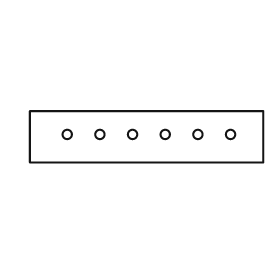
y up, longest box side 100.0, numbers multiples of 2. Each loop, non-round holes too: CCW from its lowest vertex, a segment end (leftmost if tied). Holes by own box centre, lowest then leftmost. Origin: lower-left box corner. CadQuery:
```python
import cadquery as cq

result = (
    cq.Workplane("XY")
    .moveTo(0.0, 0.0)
    .lineTo(100.0, 0.0)
    .lineTo(100.0, 22.0)
    .lineTo(0.0, 22.0)
    .close()
    .moveTo(16.0, 12.0)
    .circle(2.0)
    .moveTo(30.0, 12.0)
    .circle(2.0)
    .moveTo(44.0, 12.0)
    .circle(2.0)
    .moveTo(58.0, 12.0)
    .circle(2.0)
    .moveTo(72.0, 12.0)
    .circle(2.0)
    .moveTo(86.0, 12.0)
    .circle(2.0)
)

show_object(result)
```